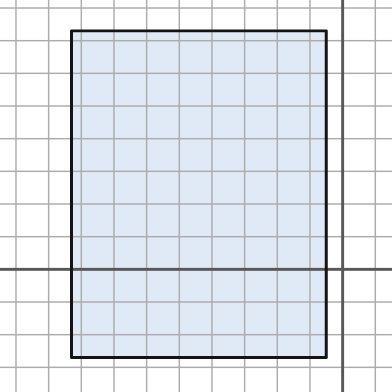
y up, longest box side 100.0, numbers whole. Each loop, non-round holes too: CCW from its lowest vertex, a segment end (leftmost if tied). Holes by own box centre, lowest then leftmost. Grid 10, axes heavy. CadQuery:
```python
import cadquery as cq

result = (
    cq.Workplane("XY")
    .moveTo(-83.0, -27.0)
    .lineTo(-5.0, -27.0)
    .lineTo(-5.0, 73.0)
    .lineTo(-83.0, 73.0)
    .close()
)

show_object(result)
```